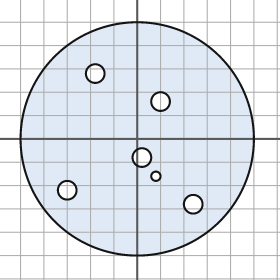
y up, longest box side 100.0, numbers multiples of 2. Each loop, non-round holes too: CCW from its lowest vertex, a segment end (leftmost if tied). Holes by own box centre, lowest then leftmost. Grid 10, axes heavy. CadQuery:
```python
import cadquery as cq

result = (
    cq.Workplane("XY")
    .moveTo(0.0, 0.0)
    .circle(50.0)
    .moveTo(24.0, -28.0)
    .circle(4.0)
    .moveTo(-30.0, -22.0)
    .circle(4.0)
    .moveTo(8.0, -16.0)
    .circle(2.0)
    .moveTo(2.0, -8.0)
    .circle(4.0)
    .moveTo(10.0, 16.0)
    .circle(4.0)
    .moveTo(-18.0, 28.0)
    .circle(4.0)
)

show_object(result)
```